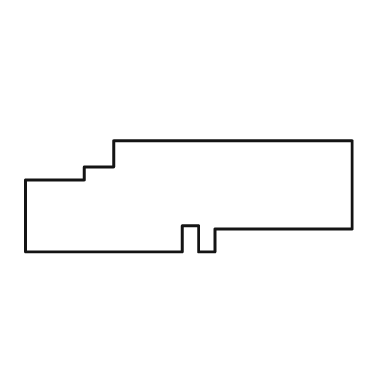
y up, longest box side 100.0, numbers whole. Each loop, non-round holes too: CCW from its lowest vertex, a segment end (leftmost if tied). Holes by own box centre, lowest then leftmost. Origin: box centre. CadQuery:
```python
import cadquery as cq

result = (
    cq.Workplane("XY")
    .moveTo(-50.0, -17.0)
    .lineTo(-2.0, -17.0)
    .lineTo(-2.0, -9.0)
    .lineTo(3.0, -9.0)
    .lineTo(3.0, -17.0)
    .lineTo(8.0, -17.0)
    .lineTo(8.0, -10.0)
    .lineTo(50.0, -10.0)
    .lineTo(50.0, 17.0)
    .lineTo(-23.0, 17.0)
    .lineTo(-23.0, 9.0)
    .lineTo(-32.0, 9.0)
    .lineTo(-32.0, 5.0)
    .lineTo(-50.0, 5.0)
    .close()
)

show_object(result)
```